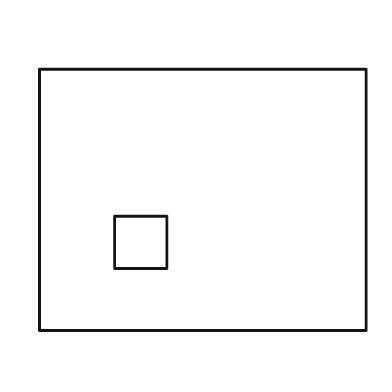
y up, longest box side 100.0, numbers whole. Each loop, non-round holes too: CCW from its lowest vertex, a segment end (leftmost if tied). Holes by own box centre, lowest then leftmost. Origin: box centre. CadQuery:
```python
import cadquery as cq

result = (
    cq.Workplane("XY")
    .moveTo(-50.0, -40.0)
    .lineTo(50.0, -40.0)
    .lineTo(50.0, 40.0)
    .lineTo(-50.0, 40.0)
    .close()
    .moveTo(-27.0, -21.0)
    .lineTo(-11.0, -21.0)
    .lineTo(-11.0, -5.0)
    .lineTo(-27.0, -5.0)
    .close()
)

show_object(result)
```